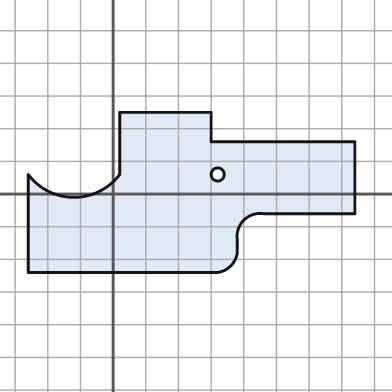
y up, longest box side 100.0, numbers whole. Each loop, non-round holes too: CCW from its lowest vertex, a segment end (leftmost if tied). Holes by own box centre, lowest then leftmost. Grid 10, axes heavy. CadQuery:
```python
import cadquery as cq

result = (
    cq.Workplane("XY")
    .moveTo(-26.0, -24.0)
    .lineTo(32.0, -24.0)
    .threePointArc((36.0, -22.0), (38.0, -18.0))
    .lineTo(38.0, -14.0)
    .threePointArc((40.0, -8.0), (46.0, -6.0))
    .lineTo(74.0, -6.0)
    .lineTo(74.0, 16.0)
    .lineTo(30.0, 16.0)
    .lineTo(30.0, 25.0)
    .lineTo(2.0, 25.0)
    .lineTo(2.0, 6.0)
    .threePointArc((-12.0, -1.0), (-26.0, 6.0))
    .close()
    .moveTo(32.0, 6.0)
    .circle(2.0)
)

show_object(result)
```